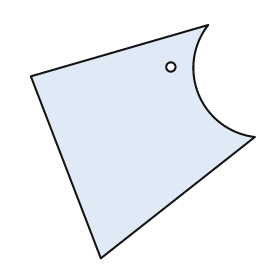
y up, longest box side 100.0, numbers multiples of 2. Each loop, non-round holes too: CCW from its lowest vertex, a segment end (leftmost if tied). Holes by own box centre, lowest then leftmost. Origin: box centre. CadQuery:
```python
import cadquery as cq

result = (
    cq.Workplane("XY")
    .moveTo(-18.0, -50.0)
    .lineTo(48.0, 2.0)
    .threePointArc((24.0, 20.0), (28.0, 50.0))
    .lineTo(-48.0, 28.0)
    .close()
    .moveTo(12.0, 32.0)
    .circle(2.0)
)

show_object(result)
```